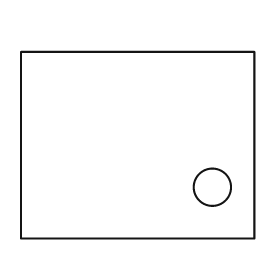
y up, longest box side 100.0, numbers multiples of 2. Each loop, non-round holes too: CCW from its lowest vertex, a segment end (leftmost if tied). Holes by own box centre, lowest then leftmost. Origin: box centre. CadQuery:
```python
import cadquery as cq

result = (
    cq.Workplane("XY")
    .moveTo(-50.0, -40.0)
    .lineTo(50.0, -40.0)
    .lineTo(50.0, 40.0)
    .lineTo(-50.0, 40.0)
    .close()
    .moveTo(32.0, -18.0)
    .circle(8.0)
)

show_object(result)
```